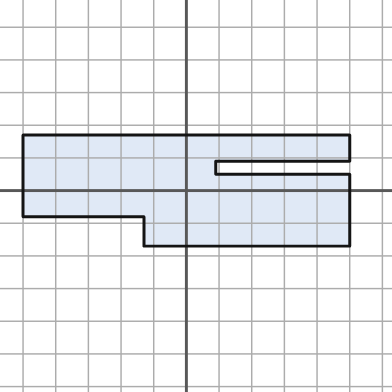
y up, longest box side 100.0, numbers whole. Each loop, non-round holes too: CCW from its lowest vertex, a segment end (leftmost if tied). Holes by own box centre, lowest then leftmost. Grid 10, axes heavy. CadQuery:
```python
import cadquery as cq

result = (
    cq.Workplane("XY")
    .moveTo(-13.0, -17.0)
    .lineTo(50.0, -17.0)
    .lineTo(50.0, 5.0)
    .lineTo(9.0, 5.0)
    .lineTo(9.0, 9.0)
    .lineTo(50.0, 9.0)
    .lineTo(50.0, 17.0)
    .lineTo(-50.0, 17.0)
    .lineTo(-50.0, -8.0)
    .lineTo(-13.0, -8.0)
    .close()
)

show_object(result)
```